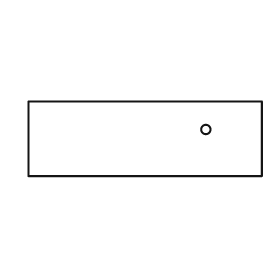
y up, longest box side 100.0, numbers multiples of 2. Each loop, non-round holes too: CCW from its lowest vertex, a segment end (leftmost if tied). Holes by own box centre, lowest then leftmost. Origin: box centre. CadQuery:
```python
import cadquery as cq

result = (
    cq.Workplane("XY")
    .moveTo(-50.0, -16.0)
    .lineTo(50.0, -16.0)
    .lineTo(50.0, 16.0)
    .lineTo(-50.0, 16.0)
    .close()
    .moveTo(26.0, 4.0)
    .circle(2.0)
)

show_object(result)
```